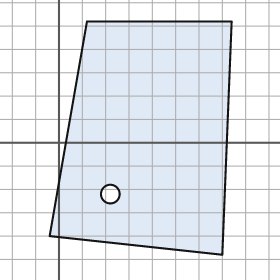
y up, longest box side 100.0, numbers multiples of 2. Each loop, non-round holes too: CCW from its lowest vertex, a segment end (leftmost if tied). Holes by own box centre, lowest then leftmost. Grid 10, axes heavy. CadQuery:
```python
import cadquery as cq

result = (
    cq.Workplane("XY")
    .moveTo(70.0, -48.0)
    .lineTo(74.0, 52.0)
    .lineTo(12.0, 52.0)
    .lineTo(-4.0, -40.0)
    .close()
    .moveTo(22.0, -22.0)
    .circle(4.0)
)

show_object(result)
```